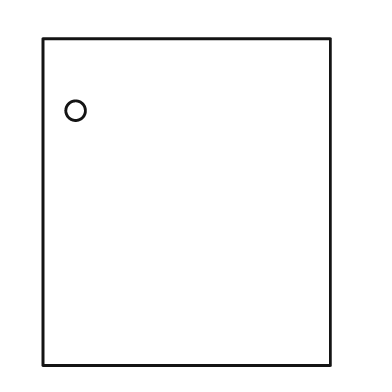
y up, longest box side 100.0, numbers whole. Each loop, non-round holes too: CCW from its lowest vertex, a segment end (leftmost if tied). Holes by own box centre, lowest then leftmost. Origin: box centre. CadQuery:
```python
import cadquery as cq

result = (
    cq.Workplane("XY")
    .moveTo(-44.0, -50.0)
    .lineTo(44.0, -50.0)
    .lineTo(44.0, 50.0)
    .lineTo(-44.0, 50.0)
    .close()
    .moveTo(-34.0, 28.0)
    .circle(3.0)
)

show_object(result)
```